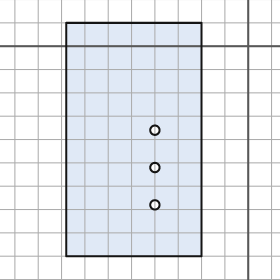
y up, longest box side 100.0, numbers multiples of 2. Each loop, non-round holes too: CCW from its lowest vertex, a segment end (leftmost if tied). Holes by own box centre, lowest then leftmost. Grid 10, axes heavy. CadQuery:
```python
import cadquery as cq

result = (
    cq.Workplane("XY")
    .moveTo(-78.0, -90.0)
    .lineTo(-20.0, -90.0)
    .lineTo(-20.0, 10.0)
    .lineTo(-78.0, 10.0)
    .close()
    .moveTo(-40.0, -68.0)
    .circle(2.0)
    .moveTo(-40.0, -52.0)
    .circle(2.0)
    .moveTo(-40.0, -36.0)
    .circle(2.0)
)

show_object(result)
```